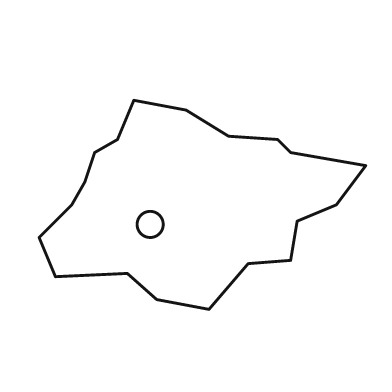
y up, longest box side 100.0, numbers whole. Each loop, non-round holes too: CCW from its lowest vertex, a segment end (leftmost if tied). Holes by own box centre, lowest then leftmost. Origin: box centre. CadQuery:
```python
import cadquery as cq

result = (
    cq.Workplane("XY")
    .moveTo(2.0, -32.0)
    .lineTo(14.0, -18.0)
    .lineTo(27.0, -17.0)
    .lineTo(29.0, -5.0)
    .lineTo(41.0, 0.0)
    .lineTo(50.0, 12.0)
    .lineTo(27.0, 16.0)
    .lineTo(23.0, 20.0)
    .lineTo(8.0, 21.0)
    .lineTo(-5.0, 29.0)
    .lineTo(-21.0, 32.0)
    .lineTo(-26.0, 20.0)
    .lineTo(-33.0, 16.0)
    .lineTo(-36.0, 7.0)
    .lineTo(-40.0, 0.0)
    .lineTo(-50.0, -10.0)
    .lineTo(-45.0, -22.0)
    .lineTo(-23.0, -21.0)
    .lineTo(-14.0, -29.0)
    .close()
    .moveTo(-16.0, -6.0)
    .circle(4.0)
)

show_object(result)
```